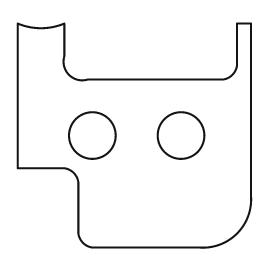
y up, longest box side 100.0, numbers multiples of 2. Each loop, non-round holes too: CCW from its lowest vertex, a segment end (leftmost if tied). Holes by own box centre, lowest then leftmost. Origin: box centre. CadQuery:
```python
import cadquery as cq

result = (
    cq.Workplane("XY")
    .moveTo(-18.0, -48.0)
    .lineTo(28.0, -48.0)
    .threePointArc((44.0, -42.0), (50.0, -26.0))
    .lineTo(50.0, 48.0)
    .lineTo(44.0, 48.0)
    .lineTo(44.0, 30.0)
    .threePointArc((42.0, 26.0), (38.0, 24.0))
    .lineTo(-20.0, 24.0)
    .threePointArc((-28.0, 26.0), (-30.0, 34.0))
    .lineTo(-30.0, 48.0)
    .threePointArc((-40.0, 46.0), (-50.0, 48.0))
    .lineTo(-50.0, -14.0)
    .lineTo(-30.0, -14.0)
    .threePointArc((-26.0, -16.0), (-24.0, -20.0))
    .lineTo(-24.0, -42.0)
    .threePointArc((-22.0, -46.0), (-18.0, -48.0))
    .close()
    .moveTo(-18.0, 0.0)
    .circle(10.0)
    .moveTo(20.0, 0.0)
    .circle(10.0)
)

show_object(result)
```